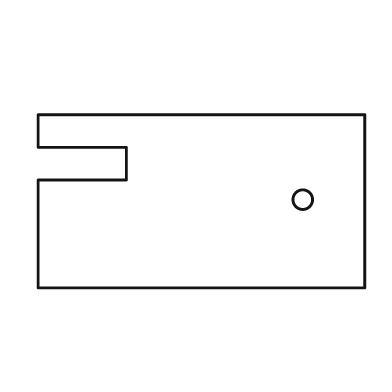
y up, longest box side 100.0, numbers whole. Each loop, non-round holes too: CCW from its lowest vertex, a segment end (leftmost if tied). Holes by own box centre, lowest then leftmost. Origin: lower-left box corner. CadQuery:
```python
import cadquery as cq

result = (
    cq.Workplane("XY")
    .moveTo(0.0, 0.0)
    .lineTo(100.0, 0.0)
    .lineTo(100.0, 53.0)
    .lineTo(0.0, 53.0)
    .lineTo(0.0, 43.0)
    .lineTo(27.0, 43.0)
    .lineTo(27.0, 33.0)
    .lineTo(0.0, 33.0)
    .close()
    .moveTo(81.0, 27.0)
    .circle(3.0)
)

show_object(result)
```